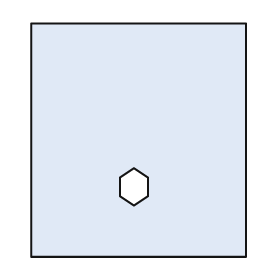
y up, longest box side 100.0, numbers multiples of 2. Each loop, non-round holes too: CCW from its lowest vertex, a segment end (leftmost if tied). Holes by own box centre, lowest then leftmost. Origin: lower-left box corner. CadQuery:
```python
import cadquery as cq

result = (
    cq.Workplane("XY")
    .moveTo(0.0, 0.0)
    .lineTo(92.0, 0.0)
    .lineTo(92.0, 100.0)
    .lineTo(0.0, 100.0)
    .close()
    .moveTo(44.0, 22.0)
    .lineTo(50.0, 26.0)
    .lineTo(50.0, 34.0)
    .lineTo(44.0, 38.0)
    .lineTo(38.0, 34.0)
    .lineTo(38.0, 26.0)
    .close()
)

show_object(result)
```